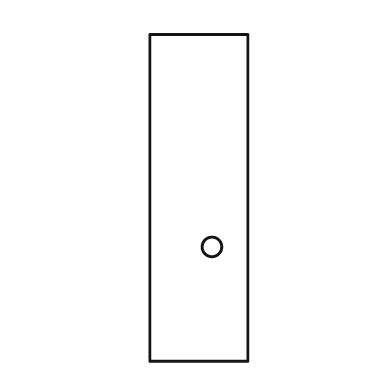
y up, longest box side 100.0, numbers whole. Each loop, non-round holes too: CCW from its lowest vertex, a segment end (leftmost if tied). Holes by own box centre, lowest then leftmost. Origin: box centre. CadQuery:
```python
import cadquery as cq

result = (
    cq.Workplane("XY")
    .moveTo(-15.0, -50.0)
    .lineTo(15.0, -50.0)
    .lineTo(15.0, 50.0)
    .lineTo(-15.0, 50.0)
    .close()
    .moveTo(4.0, -15.0)
    .circle(3.0)
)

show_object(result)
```